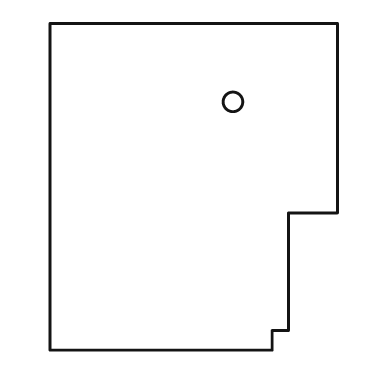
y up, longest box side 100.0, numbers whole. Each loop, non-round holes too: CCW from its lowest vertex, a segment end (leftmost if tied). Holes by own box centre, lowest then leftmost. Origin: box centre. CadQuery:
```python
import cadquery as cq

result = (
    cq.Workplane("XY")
    .moveTo(-44.0, -50.0)
    .lineTo(24.0, -50.0)
    .lineTo(24.0, -44.0)
    .lineTo(29.0, -44.0)
    .lineTo(29.0, -8.0)
    .lineTo(44.0, -8.0)
    .lineTo(44.0, 50.0)
    .lineTo(-44.0, 50.0)
    .close()
    .moveTo(12.0, 26.0)
    .circle(3.0)
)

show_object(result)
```